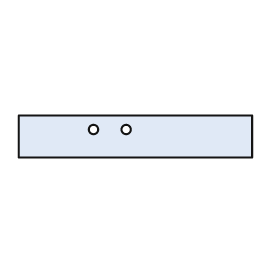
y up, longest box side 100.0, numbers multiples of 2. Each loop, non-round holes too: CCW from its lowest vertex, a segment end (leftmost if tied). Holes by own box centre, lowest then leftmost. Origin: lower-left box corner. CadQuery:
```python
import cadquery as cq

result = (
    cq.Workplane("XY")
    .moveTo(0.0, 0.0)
    .lineTo(100.0, 0.0)
    .lineTo(100.0, 18.0)
    .lineTo(0.0, 18.0)
    .close()
    .moveTo(32.0, 12.0)
    .circle(2.0)
    .moveTo(46.0, 12.0)
    .circle(2.0)
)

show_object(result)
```